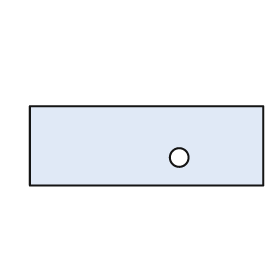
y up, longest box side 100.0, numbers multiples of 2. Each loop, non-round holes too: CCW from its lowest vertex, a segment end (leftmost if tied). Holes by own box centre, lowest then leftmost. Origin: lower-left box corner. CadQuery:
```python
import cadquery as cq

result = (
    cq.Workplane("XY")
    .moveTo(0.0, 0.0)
    .lineTo(100.0, 0.0)
    .lineTo(100.0, 34.0)
    .lineTo(0.0, 34.0)
    .close()
    .moveTo(64.0, 12.0)
    .circle(4.0)
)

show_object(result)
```